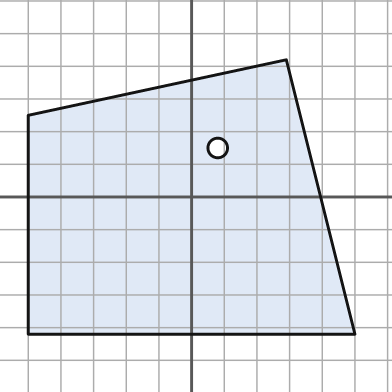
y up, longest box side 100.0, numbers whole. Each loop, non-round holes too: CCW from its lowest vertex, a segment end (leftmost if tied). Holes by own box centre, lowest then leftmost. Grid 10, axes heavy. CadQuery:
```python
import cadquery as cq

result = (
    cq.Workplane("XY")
    .moveTo(-50.0, -42.0)
    .lineTo(50.0, -42.0)
    .lineTo(29.0, 42.0)
    .lineTo(-50.0, 25.0)
    .close()
    .moveTo(8.0, 15.0)
    .circle(3.0)
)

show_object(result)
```